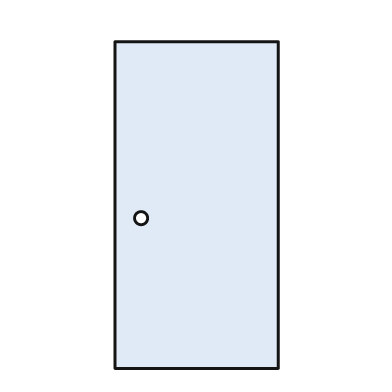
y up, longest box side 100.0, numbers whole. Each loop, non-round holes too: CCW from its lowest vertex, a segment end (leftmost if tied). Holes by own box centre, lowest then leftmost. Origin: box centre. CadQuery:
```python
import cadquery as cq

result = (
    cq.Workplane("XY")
    .moveTo(-25.0, -50.0)
    .lineTo(25.0, -50.0)
    .lineTo(25.0, 50.0)
    .lineTo(-25.0, 50.0)
    .close()
    .moveTo(-17.0, -4.0)
    .circle(2.0)
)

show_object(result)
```